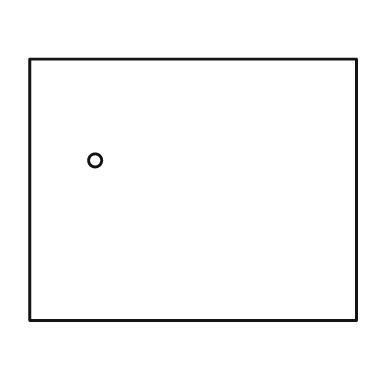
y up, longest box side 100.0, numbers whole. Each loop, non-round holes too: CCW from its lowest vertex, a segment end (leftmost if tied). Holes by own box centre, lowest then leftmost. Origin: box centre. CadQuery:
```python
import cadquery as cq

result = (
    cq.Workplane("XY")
    .moveTo(-50.0, -40.0)
    .lineTo(50.0, -40.0)
    .lineTo(50.0, 40.0)
    .lineTo(-50.0, 40.0)
    .close()
    .moveTo(-30.0, 9.0)
    .circle(2.0)
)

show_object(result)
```